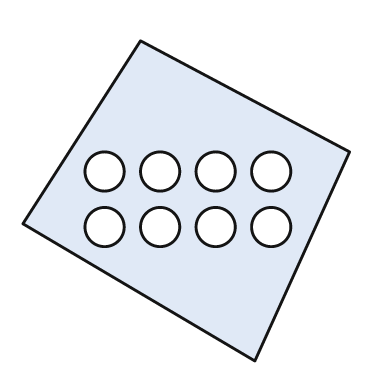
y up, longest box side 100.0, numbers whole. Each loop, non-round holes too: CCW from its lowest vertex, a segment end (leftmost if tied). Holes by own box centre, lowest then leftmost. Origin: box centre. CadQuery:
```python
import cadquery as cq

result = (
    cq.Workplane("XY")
    .moveTo(21.0, -49.0)
    .lineTo(50.0, 15.0)
    .lineTo(-14.0, 49.0)
    .lineTo(-50.0, -7.0)
    .close()
    .moveTo(-25.0, -8.0)
    .circle(6.0)
    .moveTo(-8.0, -8.0)
    .circle(6.0)
    .moveTo(9.0, -8.0)
    .circle(6.0)
    .moveTo(26.0, -8.0)
    .circle(6.0)
    .moveTo(-25.0, 9.0)
    .circle(6.0)
    .moveTo(-8.0, 9.0)
    .circle(6.0)
    .moveTo(9.0, 9.0)
    .circle(6.0)
    .moveTo(26.0, 9.0)
    .circle(6.0)
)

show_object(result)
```